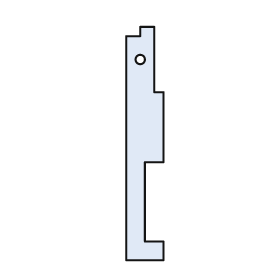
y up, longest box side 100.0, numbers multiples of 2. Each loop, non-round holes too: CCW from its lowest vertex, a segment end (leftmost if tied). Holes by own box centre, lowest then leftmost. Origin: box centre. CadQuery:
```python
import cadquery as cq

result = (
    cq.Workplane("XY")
    .moveTo(-8.0, -50.0)
    .lineTo(8.0, -50.0)
    .lineTo(8.0, -42.0)
    .lineTo(0.0, -42.0)
    .lineTo(0.0, -8.0)
    .lineTo(8.0, -8.0)
    .lineTo(8.0, 22.0)
    .lineTo(4.0, 22.0)
    .lineTo(4.0, 50.0)
    .lineTo(-2.0, 50.0)
    .lineTo(-2.0, 46.0)
    .lineTo(-8.0, 46.0)
    .close()
    .moveTo(-2.0, 36.0)
    .circle(2.0)
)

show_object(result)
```